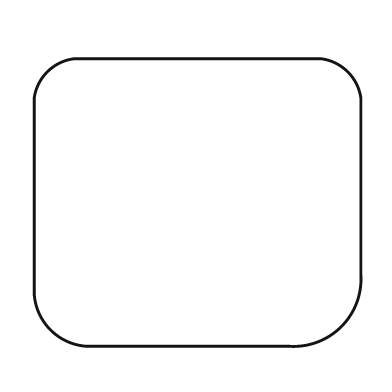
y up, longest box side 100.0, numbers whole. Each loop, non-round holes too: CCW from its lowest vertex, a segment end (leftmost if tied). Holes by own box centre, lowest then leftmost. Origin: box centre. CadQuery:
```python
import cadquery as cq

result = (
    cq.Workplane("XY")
    .moveTo(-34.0, -44.0)
    .lineTo(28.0, -44.0)
    .threePointArc((44.0, -38.0), (50.0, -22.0))
    .lineTo(50.0, 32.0)
    .threePointArc((46.0, 40.0), (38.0, 44.0))
    .lineTo(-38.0, 44.0)
    .threePointArc((-46.0, 40.0), (-50.0, 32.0))
    .lineTo(-50.0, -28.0)
    .threePointArc((-45.0, -39.0), (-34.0, -44.0))
    .close()
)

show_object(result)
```